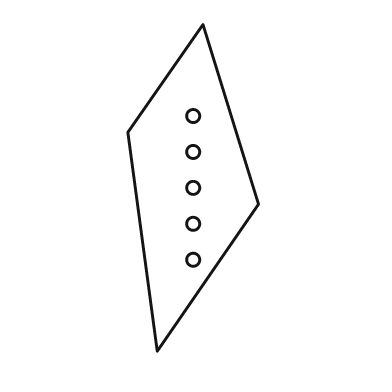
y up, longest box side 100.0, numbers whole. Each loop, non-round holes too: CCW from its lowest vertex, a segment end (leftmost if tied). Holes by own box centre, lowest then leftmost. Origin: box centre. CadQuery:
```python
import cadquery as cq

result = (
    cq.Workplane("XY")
    .moveTo(-11.0, -50.0)
    .lineTo(20.0, -5.0)
    .lineTo(3.0, 50.0)
    .lineTo(-20.0, 17.0)
    .close()
    .moveTo(0.0, -22.0)
    .circle(2.0)
    .moveTo(0.0, -11.0)
    .circle(2.0)
    .moveTo(0.0, 0.0)
    .circle(2.0)
    .moveTo(0.0, 11.0)
    .circle(2.0)
    .moveTo(0.0, 22.0)
    .circle(2.0)
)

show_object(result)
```